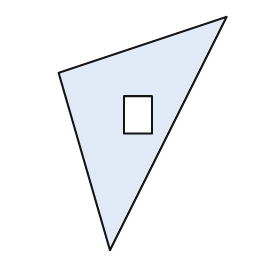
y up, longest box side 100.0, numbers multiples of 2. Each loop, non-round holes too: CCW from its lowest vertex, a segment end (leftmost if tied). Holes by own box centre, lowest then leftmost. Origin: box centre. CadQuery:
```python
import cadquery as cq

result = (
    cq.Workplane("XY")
    .moveTo(-14.0, -50.0)
    .lineTo(36.0, 50.0)
    .lineTo(-36.0, 26.0)
    .close()
    .moveTo(-8.0, 0.0)
    .lineTo(4.0, 0.0)
    .lineTo(4.0, 16.0)
    .lineTo(-8.0, 16.0)
    .close()
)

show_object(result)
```